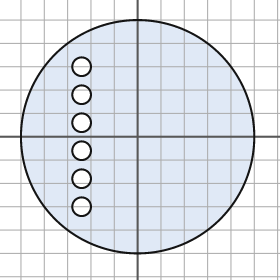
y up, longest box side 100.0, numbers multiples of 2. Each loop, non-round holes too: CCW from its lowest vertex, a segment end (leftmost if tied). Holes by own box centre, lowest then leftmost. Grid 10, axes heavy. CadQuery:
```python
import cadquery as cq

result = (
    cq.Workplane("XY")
    .moveTo(0.0, 0.0)
    .circle(50.0)
    .moveTo(-24.0, -30.0)
    .circle(4.0)
    .moveTo(-24.0, -18.0)
    .circle(4.0)
    .moveTo(-24.0, -6.0)
    .circle(4.0)
    .moveTo(-24.0, 6.0)
    .circle(4.0)
    .moveTo(-24.0, 18.0)
    .circle(4.0)
    .moveTo(-24.0, 30.0)
    .circle(4.0)
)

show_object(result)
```